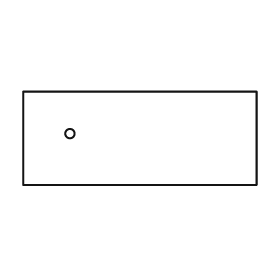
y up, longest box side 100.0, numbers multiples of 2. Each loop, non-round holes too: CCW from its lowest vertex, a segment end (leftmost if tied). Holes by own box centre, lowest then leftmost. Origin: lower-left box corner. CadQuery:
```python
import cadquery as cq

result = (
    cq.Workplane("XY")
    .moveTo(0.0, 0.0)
    .lineTo(100.0, 0.0)
    .lineTo(100.0, 40.0)
    .lineTo(0.0, 40.0)
    .close()
    .moveTo(20.0, 22.0)
    .circle(2.0)
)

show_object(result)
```